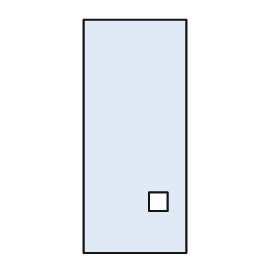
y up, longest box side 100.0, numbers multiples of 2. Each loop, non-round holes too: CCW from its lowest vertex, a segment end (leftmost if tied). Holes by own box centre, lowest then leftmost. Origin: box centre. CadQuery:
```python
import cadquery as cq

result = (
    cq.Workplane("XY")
    .moveTo(-22.0, -50.0)
    .lineTo(22.0, -50.0)
    .lineTo(22.0, 50.0)
    .lineTo(-22.0, 50.0)
    .close()
    .moveTo(6.0, -32.0)
    .lineTo(14.0, -32.0)
    .lineTo(14.0, -24.0)
    .lineTo(6.0, -24.0)
    .close()
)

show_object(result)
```